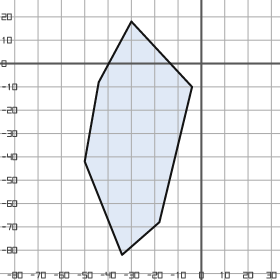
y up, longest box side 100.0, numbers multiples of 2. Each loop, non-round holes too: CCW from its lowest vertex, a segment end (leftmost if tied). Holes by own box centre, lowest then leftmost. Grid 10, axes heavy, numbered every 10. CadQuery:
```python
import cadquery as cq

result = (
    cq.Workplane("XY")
    .moveTo(-34.0, -82.0)
    .lineTo(-18.0, -68.0)
    .lineTo(-4.0, -10.0)
    .lineTo(-30.0, 18.0)
    .lineTo(-44.0, -8.0)
    .lineTo(-50.0, -42.0)
    .close()
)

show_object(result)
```